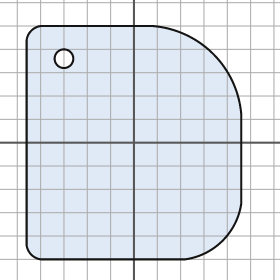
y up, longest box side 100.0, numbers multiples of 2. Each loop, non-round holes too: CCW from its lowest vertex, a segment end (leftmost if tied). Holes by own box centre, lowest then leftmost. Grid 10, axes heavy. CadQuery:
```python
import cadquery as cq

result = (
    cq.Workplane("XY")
    .moveTo(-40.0, -50.0)
    .lineTo(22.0, -50.0)
    .threePointArc((38.0, -42.0), (46.0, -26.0))
    .lineTo(46.0, 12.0)
    .threePointArc((34.0, 38.0), (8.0, 50.0))
    .lineTo(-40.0, 50.0)
    .threePointArc((-44.0, 48.0), (-46.0, 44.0))
    .lineTo(-46.0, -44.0)
    .threePointArc((-44.0, -48.0), (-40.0, -50.0))
    .close()
    .moveTo(-30.0, 36.0)
    .circle(4.0)
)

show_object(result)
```